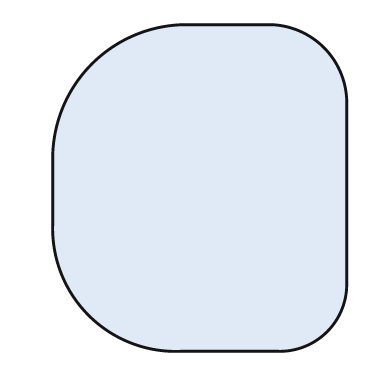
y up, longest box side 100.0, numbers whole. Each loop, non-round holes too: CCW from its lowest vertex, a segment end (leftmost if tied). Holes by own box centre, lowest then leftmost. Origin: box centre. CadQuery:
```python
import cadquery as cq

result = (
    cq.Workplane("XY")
    .moveTo(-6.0, -50.0)
    .lineTo(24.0, -50.0)
    .threePointArc((39.0, -44.0), (45.0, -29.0))
    .lineTo(45.0, 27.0)
    .threePointArc((38.0, 43.0), (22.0, 50.0))
    .lineTo(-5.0, 50.0)
    .threePointArc((-33.0, 38.0), (-45.0, 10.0))
    .lineTo(-45.0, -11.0)
    .threePointArc((-34.0, -39.0), (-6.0, -50.0))
    .close()
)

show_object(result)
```